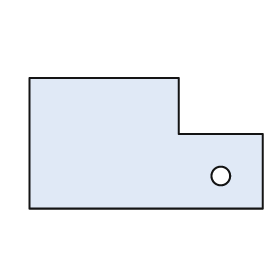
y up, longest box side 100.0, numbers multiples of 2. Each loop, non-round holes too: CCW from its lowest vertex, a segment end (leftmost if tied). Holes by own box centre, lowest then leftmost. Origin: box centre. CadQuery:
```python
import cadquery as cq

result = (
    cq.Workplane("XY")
    .moveTo(-50.0, -28.0)
    .lineTo(50.0, -28.0)
    .lineTo(50.0, 4.0)
    .lineTo(14.0, 4.0)
    .lineTo(14.0, 28.0)
    .lineTo(-50.0, 28.0)
    .close()
    .moveTo(32.0, -14.0)
    .circle(4.0)
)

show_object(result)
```